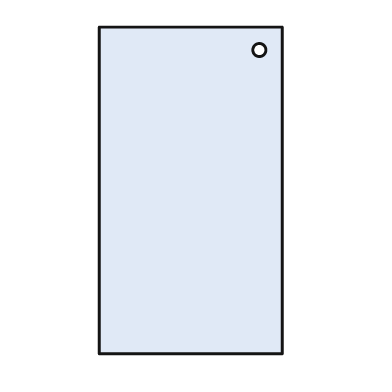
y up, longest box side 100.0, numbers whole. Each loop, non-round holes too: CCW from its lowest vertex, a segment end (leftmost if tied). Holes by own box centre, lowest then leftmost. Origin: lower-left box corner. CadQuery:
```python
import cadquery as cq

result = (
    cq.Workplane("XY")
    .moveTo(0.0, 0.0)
    .lineTo(56.0, 0.0)
    .lineTo(56.0, 100.0)
    .lineTo(0.0, 100.0)
    .close()
    .moveTo(49.0, 93.0)
    .circle(2.0)
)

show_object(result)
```